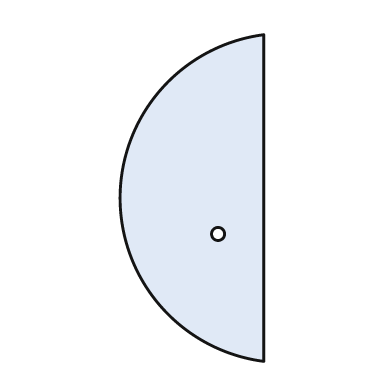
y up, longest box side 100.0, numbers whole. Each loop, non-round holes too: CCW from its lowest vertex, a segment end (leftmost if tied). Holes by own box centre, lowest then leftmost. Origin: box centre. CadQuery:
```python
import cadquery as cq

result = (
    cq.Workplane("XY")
    .moveTo(22.0, -50.0)
    .lineTo(22.0, 50.0)
    .threePointArc((-22.0, 0.0), (22.0, -50.0))
    .close()
    .moveTo(8.0, -11.0)
    .circle(2.0)
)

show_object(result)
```